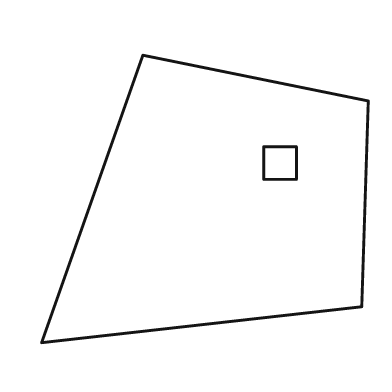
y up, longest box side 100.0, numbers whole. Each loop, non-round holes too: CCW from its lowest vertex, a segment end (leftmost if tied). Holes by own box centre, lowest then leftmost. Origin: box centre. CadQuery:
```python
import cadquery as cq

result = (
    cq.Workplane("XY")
    .moveTo(-50.0, -44.0)
    .lineTo(48.0, -33.0)
    .lineTo(50.0, 30.0)
    .lineTo(-19.0, 44.0)
    .close()
    .moveTo(18.0, 6.0)
    .lineTo(28.0, 6.0)
    .lineTo(28.0, 16.0)
    .lineTo(18.0, 16.0)
    .close()
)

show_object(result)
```